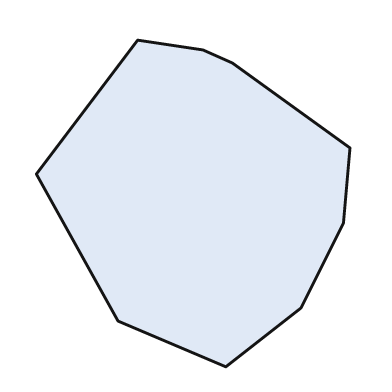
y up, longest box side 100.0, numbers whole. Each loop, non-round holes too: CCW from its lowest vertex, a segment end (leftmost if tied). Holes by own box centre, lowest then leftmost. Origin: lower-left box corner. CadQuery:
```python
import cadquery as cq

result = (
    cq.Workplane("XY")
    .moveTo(58.0, 0.0)
    .lineTo(81.0, 18.0)
    .lineTo(94.0, 44.0)
    .lineTo(96.0, 67.0)
    .lineTo(60.0, 93.0)
    .lineTo(51.0, 97.0)
    .lineTo(31.0, 100.0)
    .lineTo(0.0, 59.0)
    .lineTo(25.0, 14.0)
    .close()
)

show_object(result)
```